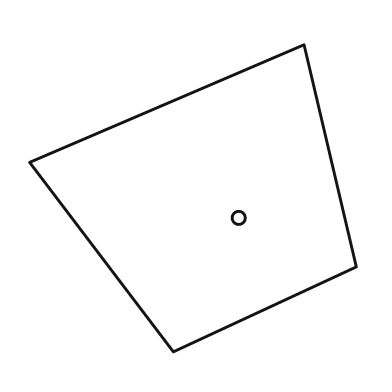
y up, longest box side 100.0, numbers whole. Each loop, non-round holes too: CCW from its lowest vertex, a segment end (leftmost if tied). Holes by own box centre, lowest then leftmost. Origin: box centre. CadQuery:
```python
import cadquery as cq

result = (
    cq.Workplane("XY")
    .moveTo(-6.0, -47.0)
    .lineTo(50.0, -21.0)
    .lineTo(34.0, 47.0)
    .lineTo(-50.0, 11.0)
    .close()
    .moveTo(14.0, -6.0)
    .circle(2.0)
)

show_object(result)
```